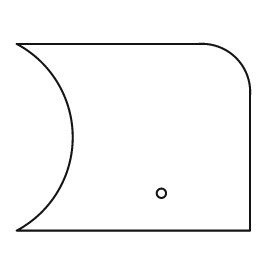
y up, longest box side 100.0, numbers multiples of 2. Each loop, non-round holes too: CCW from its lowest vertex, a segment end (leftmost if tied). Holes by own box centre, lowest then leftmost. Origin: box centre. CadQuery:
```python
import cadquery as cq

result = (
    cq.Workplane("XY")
    .moveTo(-50.0, -40.0)
    .lineTo(50.0, -40.0)
    .lineTo(50.0, 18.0)
    .threePointArc((44.0, 34.0), (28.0, 40.0))
    .lineTo(-50.0, 40.0)
    .threePointArc((-26.0, 0.0), (-50.0, -40.0))
    .close()
    .moveTo(12.0, -24.0)
    .circle(2.0)
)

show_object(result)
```